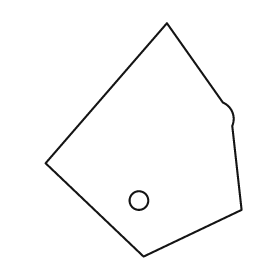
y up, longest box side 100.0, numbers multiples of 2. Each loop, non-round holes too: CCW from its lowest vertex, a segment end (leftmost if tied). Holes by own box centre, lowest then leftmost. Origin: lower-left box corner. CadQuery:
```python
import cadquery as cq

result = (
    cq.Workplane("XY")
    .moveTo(42.0, 0.0)
    .lineTo(84.0, 20.0)
    .lineTo(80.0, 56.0)
    .threePointArc((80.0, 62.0), (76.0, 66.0))
    .lineTo(52.0, 100.0)
    .lineTo(0.0, 40.0)
    .close()
    .moveTo(40.0, 24.0)
    .circle(4.0)
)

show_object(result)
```